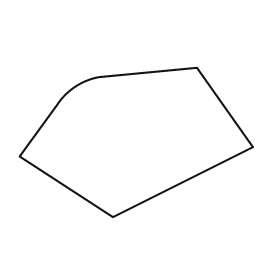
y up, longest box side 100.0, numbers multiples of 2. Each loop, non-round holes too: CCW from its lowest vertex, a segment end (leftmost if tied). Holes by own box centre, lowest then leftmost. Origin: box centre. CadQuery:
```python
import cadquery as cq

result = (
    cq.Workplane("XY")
    .moveTo(-10.0, -32.0)
    .lineTo(50.0, -2.0)
    .lineTo(26.0, 32.0)
    .lineTo(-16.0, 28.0)
    .threePointArc((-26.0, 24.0), (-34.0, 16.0))
    .lineTo(-50.0, -6.0)
    .close()
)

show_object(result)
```